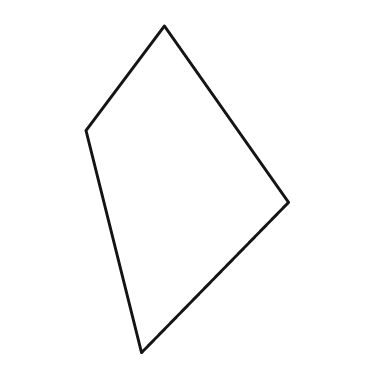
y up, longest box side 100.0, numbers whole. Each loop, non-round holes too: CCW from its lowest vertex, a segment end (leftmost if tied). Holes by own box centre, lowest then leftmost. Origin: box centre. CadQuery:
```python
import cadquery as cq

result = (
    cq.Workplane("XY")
    .moveTo(-14.0, -50.0)
    .lineTo(31.0, -4.0)
    .lineTo(-7.0, 50.0)
    .lineTo(-31.0, 18.0)
    .close()
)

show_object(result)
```